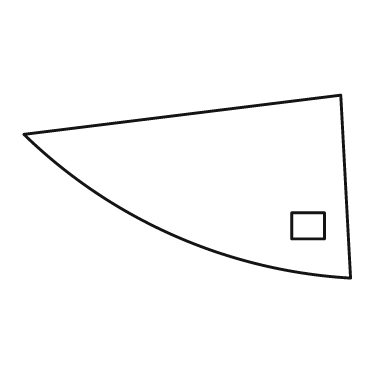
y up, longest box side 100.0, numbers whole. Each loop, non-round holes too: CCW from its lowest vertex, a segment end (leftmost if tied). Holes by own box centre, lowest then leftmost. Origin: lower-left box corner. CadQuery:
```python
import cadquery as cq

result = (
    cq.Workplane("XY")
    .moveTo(100.0, 0.0)
    .lineTo(97.0, 56.0)
    .lineTo(0.0, 44.0)
    .threePointArc((46.0, 13.0), (100.0, 0.0))
    .close()
    .moveTo(82.0, 12.0)
    .lineTo(92.0, 12.0)
    .lineTo(92.0, 20.0)
    .lineTo(82.0, 20.0)
    .close()
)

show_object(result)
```